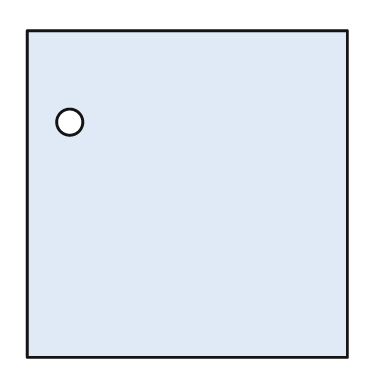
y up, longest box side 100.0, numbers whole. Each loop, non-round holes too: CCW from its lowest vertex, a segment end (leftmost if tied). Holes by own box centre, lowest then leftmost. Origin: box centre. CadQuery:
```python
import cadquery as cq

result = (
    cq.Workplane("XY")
    .moveTo(-49.0, -50.0)
    .lineTo(49.0, -50.0)
    .lineTo(49.0, 50.0)
    .lineTo(-49.0, 50.0)
    .close()
    .moveTo(-36.0, 22.0)
    .circle(4.0)
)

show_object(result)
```